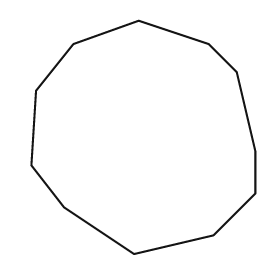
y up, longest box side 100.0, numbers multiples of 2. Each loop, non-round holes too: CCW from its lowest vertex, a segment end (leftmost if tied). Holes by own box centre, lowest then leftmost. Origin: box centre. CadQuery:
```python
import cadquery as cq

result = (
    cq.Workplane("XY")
    .moveTo(-4.0, -50.0)
    .lineTo(30.0, -42.0)
    .lineTo(48.0, -24.0)
    .lineTo(48.0, -6.0)
    .lineTo(40.0, 28.0)
    .lineTo(28.0, 40.0)
    .lineTo(-2.0, 50.0)
    .lineTo(-30.0, 40.0)
    .lineTo(-46.0, 20.0)
    .lineTo(-48.0, -12.0)
    .lineTo(-34.0, -30.0)
    .close()
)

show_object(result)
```